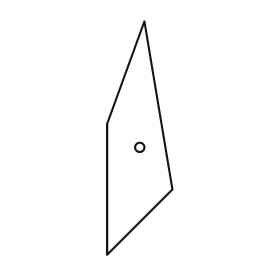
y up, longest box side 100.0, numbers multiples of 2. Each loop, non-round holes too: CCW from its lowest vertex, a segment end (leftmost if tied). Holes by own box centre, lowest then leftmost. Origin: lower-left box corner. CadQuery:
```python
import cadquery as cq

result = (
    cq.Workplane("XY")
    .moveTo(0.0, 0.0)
    .lineTo(28.0, 28.0)
    .lineTo(16.0, 100.0)
    .lineTo(0.0, 56.0)
    .close()
    .moveTo(14.0, 46.0)
    .circle(2.0)
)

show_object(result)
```